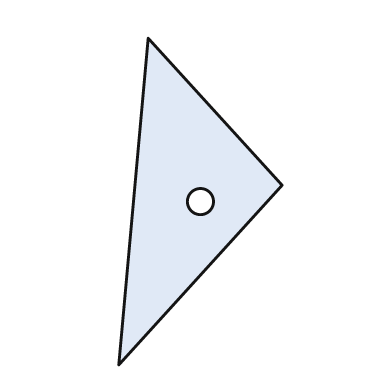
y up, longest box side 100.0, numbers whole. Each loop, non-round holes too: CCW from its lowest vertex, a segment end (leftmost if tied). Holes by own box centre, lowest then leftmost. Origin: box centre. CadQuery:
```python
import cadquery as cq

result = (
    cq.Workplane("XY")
    .moveTo(-25.0, -50.0)
    .lineTo(25.0, 5.0)
    .lineTo(-16.0, 50.0)
    .close()
    .moveTo(0.0, 0.0)
    .circle(4.0)
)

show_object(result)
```